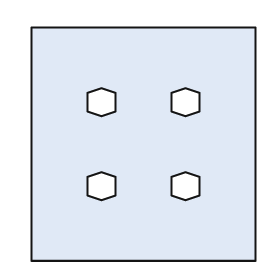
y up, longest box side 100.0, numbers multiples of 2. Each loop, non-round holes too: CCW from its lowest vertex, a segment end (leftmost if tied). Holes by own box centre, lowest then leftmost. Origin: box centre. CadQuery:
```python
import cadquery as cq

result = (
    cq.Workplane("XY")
    .moveTo(-48.0, -50.0)
    .lineTo(48.0, -50.0)
    .lineTo(48.0, 50.0)
    .lineTo(-48.0, 50.0)
    .close()
    .moveTo(-18.0, -24.0)
    .lineTo(-12.0, -22.0)
    .lineTo(-12.0, -14.0)
    .lineTo(-18.0, -12.0)
    .lineTo(-24.0, -14.0)
    .lineTo(-24.0, -22.0)
    .close()
    .moveTo(18.0, -24.0)
    .lineTo(24.0, -22.0)
    .lineTo(24.0, -14.0)
    .lineTo(18.0, -12.0)
    .lineTo(12.0, -14.0)
    .lineTo(12.0, -22.0)
    .close()
    .moveTo(-18.0, 12.0)
    .lineTo(-12.0, 14.0)
    .lineTo(-12.0, 22.0)
    .lineTo(-18.0, 24.0)
    .lineTo(-24.0, 22.0)
    .lineTo(-24.0, 14.0)
    .close()
    .moveTo(18.0, 12.0)
    .lineTo(24.0, 14.0)
    .lineTo(24.0, 22.0)
    .lineTo(18.0, 24.0)
    .lineTo(12.0, 22.0)
    .lineTo(12.0, 14.0)
    .close()
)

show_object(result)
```